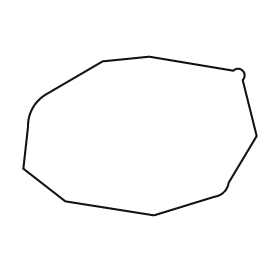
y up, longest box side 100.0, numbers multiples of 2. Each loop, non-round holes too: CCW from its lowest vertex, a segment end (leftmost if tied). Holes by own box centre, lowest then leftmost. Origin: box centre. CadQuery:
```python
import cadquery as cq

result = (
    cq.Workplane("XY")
    .moveTo(6.0, -34.0)
    .lineTo(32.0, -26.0)
    .threePointArc((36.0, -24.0), (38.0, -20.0))
    .lineTo(50.0, 0.0)
    .lineTo(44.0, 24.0)
    .threePointArc((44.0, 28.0), (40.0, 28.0))
    .lineTo(4.0, 34.0)
    .lineTo(-16.0, 32.0)
    .lineTo(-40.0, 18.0)
    .threePointArc((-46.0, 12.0), (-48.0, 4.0))
    .lineTo(-50.0, -14.0)
    .lineTo(-32.0, -28.0)
    .close()
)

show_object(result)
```